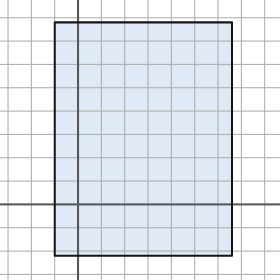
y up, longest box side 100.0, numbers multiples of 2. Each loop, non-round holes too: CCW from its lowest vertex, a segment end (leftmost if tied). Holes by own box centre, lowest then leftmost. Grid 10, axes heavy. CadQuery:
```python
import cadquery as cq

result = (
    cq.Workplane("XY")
    .moveTo(-10.0, -22.0)
    .lineTo(66.0, -22.0)
    .lineTo(66.0, 78.0)
    .lineTo(-10.0, 78.0)
    .close()
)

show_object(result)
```